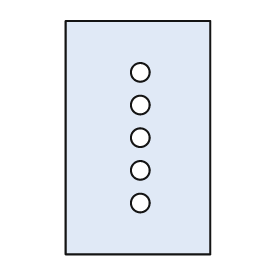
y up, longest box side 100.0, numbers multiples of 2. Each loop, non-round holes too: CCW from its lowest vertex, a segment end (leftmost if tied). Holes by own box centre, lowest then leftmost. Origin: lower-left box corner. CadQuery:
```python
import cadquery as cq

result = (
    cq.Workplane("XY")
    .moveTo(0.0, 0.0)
    .lineTo(62.0, 0.0)
    .lineTo(62.0, 100.0)
    .lineTo(0.0, 100.0)
    .close()
    .moveTo(32.0, 22.0)
    .circle(4.0)
    .moveTo(32.0, 36.0)
    .circle(4.0)
    .moveTo(32.0, 50.0)
    .circle(4.0)
    .moveTo(32.0, 64.0)
    .circle(4.0)
    .moveTo(32.0, 78.0)
    .circle(4.0)
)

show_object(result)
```